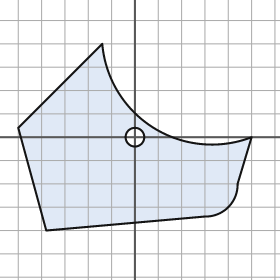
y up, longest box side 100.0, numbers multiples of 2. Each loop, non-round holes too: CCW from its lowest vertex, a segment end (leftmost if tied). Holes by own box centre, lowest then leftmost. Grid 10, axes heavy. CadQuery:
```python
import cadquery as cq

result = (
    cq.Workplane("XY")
    .moveTo(-38.0, -40.0)
    .lineTo(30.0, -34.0)
    .threePointArc((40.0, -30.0), (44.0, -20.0))
    .lineTo(50.0, 0.0)
    .threePointArc((8.0, 4.0), (-14.0, 40.0))
    .lineTo(-50.0, 4.0)
    .close()
    .moveTo(0.0, 0.0)
    .circle(4.0)
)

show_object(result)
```